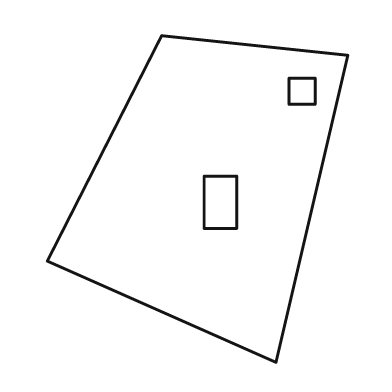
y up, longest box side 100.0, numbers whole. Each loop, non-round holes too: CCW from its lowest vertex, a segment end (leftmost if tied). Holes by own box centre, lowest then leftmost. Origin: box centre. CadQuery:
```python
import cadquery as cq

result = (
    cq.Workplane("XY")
    .moveTo(24.0, -50.0)
    .lineTo(46.0, 44.0)
    .lineTo(-11.0, 50.0)
    .lineTo(-46.0, -19.0)
    .close()
    .moveTo(2.0, -9.0)
    .lineTo(12.0, -9.0)
    .lineTo(12.0, 7.0)
    .lineTo(2.0, 7.0)
    .close()
    .moveTo(28.0, 29.0)
    .lineTo(36.0, 29.0)
    .lineTo(36.0, 37.0)
    .lineTo(28.0, 37.0)
    .close()
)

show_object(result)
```